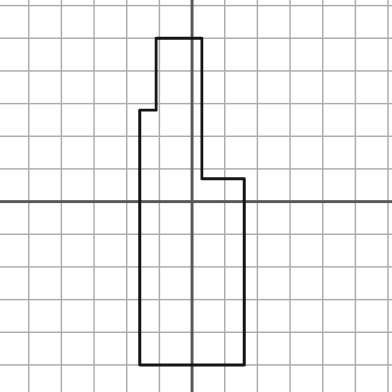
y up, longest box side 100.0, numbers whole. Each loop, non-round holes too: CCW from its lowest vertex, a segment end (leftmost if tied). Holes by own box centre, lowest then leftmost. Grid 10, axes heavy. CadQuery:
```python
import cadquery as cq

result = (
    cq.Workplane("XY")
    .moveTo(-16.0, -50.0)
    .lineTo(16.0, -50.0)
    .lineTo(16.0, 7.0)
    .lineTo(3.0, 7.0)
    .lineTo(3.0, 50.0)
    .lineTo(-11.0, 50.0)
    .lineTo(-11.0, 28.0)
    .lineTo(-16.0, 28.0)
    .close()
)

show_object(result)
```